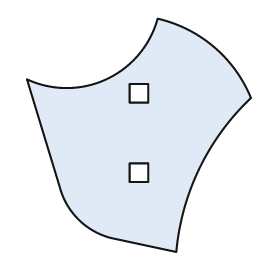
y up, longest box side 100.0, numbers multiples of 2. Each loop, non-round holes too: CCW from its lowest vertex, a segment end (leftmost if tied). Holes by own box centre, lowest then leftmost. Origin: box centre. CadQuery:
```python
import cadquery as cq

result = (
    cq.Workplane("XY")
    .moveTo(16.0, -50.0)
    .threePointArc((26.0, -14.0), (48.0, 16.0))
    .threePointArc((32.0, 38.0), (8.0, 50.0))
    .threePointArc((-14.0, 24.0), (-48.0, 24.0))
    .lineTo(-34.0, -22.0)
    .threePointArc((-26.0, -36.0), (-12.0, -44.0))
    .close()
    .moveTo(-4.0, -20.0)
    .lineTo(4.0, -20.0)
    .lineTo(4.0, -12.0)
    .lineTo(-4.0, -12.0)
    .close()
    .moveTo(-4.0, 14.0)
    .lineTo(4.0, 14.0)
    .lineTo(4.0, 22.0)
    .lineTo(-4.0, 22.0)
    .close()
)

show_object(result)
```